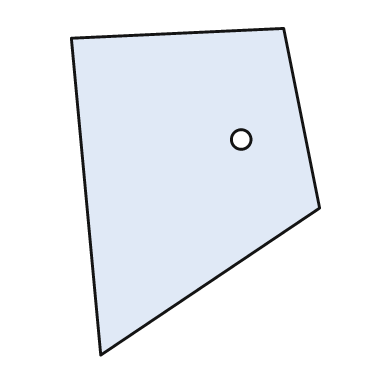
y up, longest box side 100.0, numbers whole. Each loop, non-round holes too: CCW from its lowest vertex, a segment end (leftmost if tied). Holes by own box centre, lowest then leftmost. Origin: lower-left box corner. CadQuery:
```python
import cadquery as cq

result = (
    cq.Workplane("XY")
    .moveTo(9.0, 0.0)
    .lineTo(76.0, 45.0)
    .lineTo(65.0, 100.0)
    .lineTo(0.0, 97.0)
    .close()
    .moveTo(52.0, 66.0)
    .circle(3.0)
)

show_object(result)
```